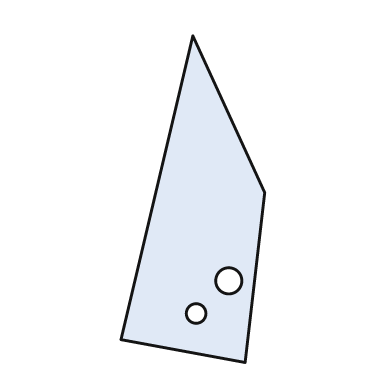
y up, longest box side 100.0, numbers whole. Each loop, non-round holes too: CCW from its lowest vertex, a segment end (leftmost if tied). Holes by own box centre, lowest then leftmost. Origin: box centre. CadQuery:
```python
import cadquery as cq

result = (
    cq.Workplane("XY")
    .moveTo(16.0, -50.0)
    .lineTo(22.0, 2.0)
    .lineTo(0.0, 50.0)
    .lineTo(-22.0, -43.0)
    .close()
    .moveTo(1.0, -35.0)
    .circle(3.0)
    .moveTo(11.0, -25.0)
    .circle(4.0)
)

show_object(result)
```